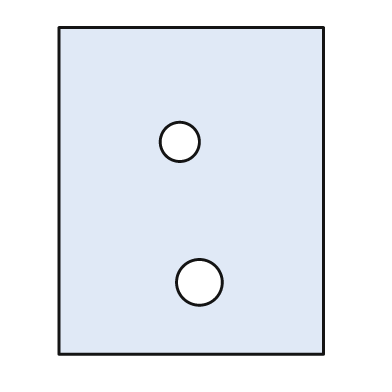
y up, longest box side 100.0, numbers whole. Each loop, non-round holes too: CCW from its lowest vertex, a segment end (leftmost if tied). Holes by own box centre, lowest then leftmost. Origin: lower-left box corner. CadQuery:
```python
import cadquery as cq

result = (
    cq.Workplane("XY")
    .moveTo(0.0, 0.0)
    .lineTo(81.0, 0.0)
    .lineTo(81.0, 100.0)
    .lineTo(0.0, 100.0)
    .close()
    .moveTo(43.0, 22.0)
    .circle(7.0)
    .moveTo(37.0, 65.0)
    .circle(6.0)
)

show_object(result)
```